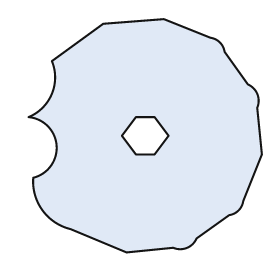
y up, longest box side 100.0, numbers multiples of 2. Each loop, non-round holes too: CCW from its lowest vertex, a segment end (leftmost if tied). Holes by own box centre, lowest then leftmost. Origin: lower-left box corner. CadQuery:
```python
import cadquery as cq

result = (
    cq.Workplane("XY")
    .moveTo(42.0, 0.0)
    .lineTo(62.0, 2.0)
    .threePointArc((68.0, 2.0), (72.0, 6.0))
    .lineTo(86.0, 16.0)
    .threePointArc((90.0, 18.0), (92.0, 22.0))
    .lineTo(100.0, 42.0)
    .lineTo(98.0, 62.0)
    .threePointArc((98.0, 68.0), (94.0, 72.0))
    .lineTo(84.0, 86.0)
    .threePointArc((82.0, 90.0), (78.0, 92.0))
    .lineTo(58.0, 100.0)
    .lineTo(32.0, 98.0)
    .lineTo(10.0, 82.0)
    .threePointArc((10.0, 68.0), (0.0, 58.0))
    .threePointArc((12.0, 46.0), (2.0, 32.0))
    .threePointArc((6.0, 18.0), (18.0, 10.0))
    .close()
    .moveTo(46.0, 42.0)
    .lineTo(54.0, 42.0)
    .lineTo(60.0, 50.0)
    .lineTo(54.0, 58.0)
    .lineTo(46.0, 58.0)
    .lineTo(40.0, 50.0)
    .close()
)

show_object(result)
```